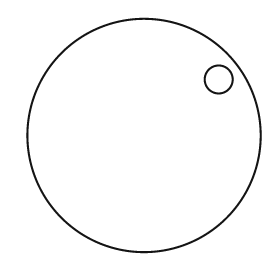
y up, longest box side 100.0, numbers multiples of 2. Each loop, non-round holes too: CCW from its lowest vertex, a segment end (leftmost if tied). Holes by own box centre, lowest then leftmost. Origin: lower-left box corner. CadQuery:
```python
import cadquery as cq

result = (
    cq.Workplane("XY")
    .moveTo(50.0, 50.0)
    .circle(50.0)
    .moveTo(82.0, 74.0)
    .circle(6.0)
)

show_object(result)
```